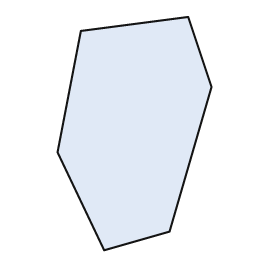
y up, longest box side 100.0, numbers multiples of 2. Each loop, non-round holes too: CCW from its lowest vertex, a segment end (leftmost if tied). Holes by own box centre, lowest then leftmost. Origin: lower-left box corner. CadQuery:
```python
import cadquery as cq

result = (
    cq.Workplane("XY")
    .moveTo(20.0, 0.0)
    .lineTo(48.0, 8.0)
    .lineTo(66.0, 70.0)
    .lineTo(56.0, 100.0)
    .lineTo(10.0, 94.0)
    .lineTo(0.0, 42.0)
    .close()
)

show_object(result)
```